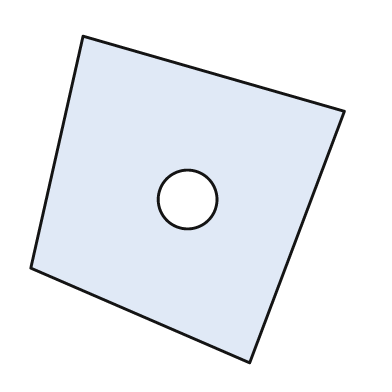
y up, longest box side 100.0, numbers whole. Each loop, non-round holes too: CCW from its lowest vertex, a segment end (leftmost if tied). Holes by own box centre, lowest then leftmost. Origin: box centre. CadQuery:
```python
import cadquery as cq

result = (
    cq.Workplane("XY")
    .moveTo(19.0, -50.0)
    .lineTo(48.0, 27.0)
    .lineTo(-32.0, 50.0)
    .lineTo(-48.0, -21.0)
    .close()
    .moveTo(0.0, 0.0)
    .circle(9.0)
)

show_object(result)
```